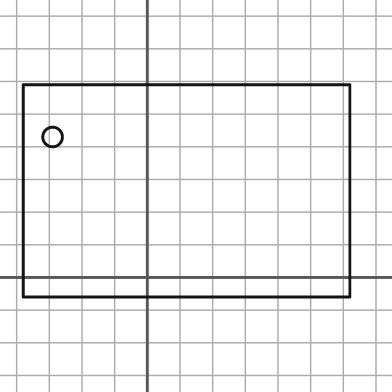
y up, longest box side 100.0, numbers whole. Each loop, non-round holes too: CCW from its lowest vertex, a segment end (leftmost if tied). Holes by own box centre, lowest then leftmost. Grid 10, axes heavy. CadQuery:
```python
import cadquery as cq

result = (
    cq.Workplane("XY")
    .moveTo(-38.0, -6.0)
    .lineTo(62.0, -6.0)
    .lineTo(62.0, 59.0)
    .lineTo(-38.0, 59.0)
    .close()
    .moveTo(-29.0, 43.0)
    .circle(3.0)
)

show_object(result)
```